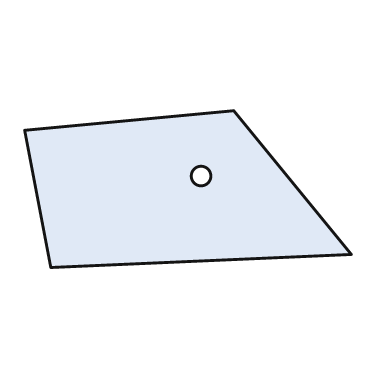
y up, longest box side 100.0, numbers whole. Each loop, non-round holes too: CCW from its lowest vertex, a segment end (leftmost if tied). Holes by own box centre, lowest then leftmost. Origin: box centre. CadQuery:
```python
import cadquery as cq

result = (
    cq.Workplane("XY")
    .moveTo(-42.0, -24.0)
    .lineTo(50.0, -20.0)
    .lineTo(14.0, 24.0)
    .lineTo(-50.0, 18.0)
    .close()
    .moveTo(4.0, 4.0)
    .circle(3.0)
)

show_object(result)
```